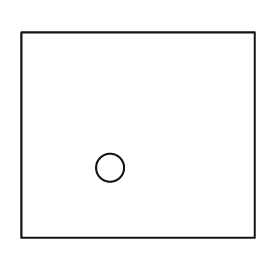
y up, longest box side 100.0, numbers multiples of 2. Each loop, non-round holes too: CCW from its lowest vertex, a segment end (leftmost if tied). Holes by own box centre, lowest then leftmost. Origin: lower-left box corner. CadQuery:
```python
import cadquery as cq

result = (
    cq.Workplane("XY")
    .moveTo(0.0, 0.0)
    .lineTo(100.0, 0.0)
    .lineTo(100.0, 88.0)
    .lineTo(0.0, 88.0)
    .close()
    .moveTo(38.0, 30.0)
    .circle(6.0)
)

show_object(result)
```